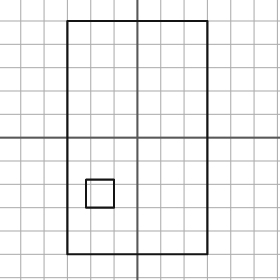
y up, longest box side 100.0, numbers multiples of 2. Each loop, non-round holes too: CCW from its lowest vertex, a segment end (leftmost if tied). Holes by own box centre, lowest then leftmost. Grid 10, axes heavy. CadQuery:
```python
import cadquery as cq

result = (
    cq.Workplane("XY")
    .moveTo(-30.0, -50.0)
    .lineTo(30.0, -50.0)
    .lineTo(30.0, 50.0)
    .lineTo(-30.0, 50.0)
    .close()
    .moveTo(-22.0, -30.0)
    .lineTo(-10.0, -30.0)
    .lineTo(-10.0, -18.0)
    .lineTo(-22.0, -18.0)
    .close()
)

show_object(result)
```